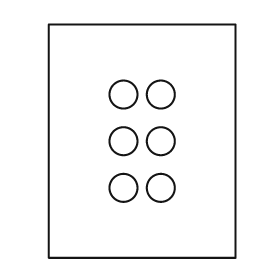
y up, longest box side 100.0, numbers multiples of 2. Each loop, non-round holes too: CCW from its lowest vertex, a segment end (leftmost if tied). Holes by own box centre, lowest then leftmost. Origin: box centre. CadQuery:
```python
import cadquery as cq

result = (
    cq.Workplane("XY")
    .moveTo(-40.0, -50.0)
    .lineTo(40.0, -50.0)
    .lineTo(40.0, 50.0)
    .lineTo(-40.0, 50.0)
    .close()
    .moveTo(-8.0, -20.0)
    .circle(6.0)
    .moveTo(8.0, -20.0)
    .circle(6.0)
    .moveTo(-8.0, 0.0)
    .circle(6.0)
    .moveTo(8.0, 0.0)
    .circle(6.0)
    .moveTo(-8.0, 20.0)
    .circle(6.0)
    .moveTo(8.0, 20.0)
    .circle(6.0)
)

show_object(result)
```